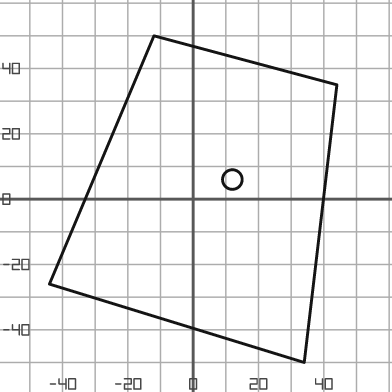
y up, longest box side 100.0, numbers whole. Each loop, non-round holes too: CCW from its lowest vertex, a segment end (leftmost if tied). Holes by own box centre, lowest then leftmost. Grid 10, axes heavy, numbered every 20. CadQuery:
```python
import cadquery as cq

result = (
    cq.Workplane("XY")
    .moveTo(34.0, -50.0)
    .lineTo(44.0, 35.0)
    .lineTo(-12.0, 50.0)
    .lineTo(-44.0, -26.0)
    .close()
    .moveTo(12.0, 6.0)
    .circle(3.0)
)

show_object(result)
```